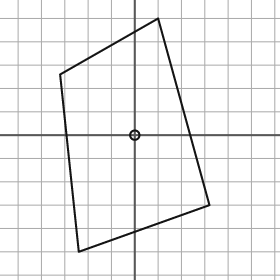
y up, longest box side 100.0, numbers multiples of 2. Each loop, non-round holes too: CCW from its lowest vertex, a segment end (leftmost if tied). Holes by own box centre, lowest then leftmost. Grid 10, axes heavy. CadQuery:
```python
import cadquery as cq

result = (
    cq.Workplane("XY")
    .moveTo(-24.0, -50.0)
    .lineTo(32.0, -30.0)
    .lineTo(10.0, 50.0)
    .lineTo(-32.0, 26.0)
    .close()
    .moveTo(0.0, 0.0)
    .circle(2.0)
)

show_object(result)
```